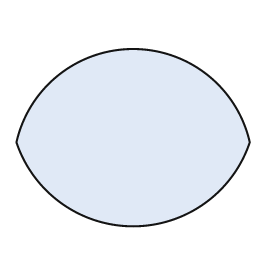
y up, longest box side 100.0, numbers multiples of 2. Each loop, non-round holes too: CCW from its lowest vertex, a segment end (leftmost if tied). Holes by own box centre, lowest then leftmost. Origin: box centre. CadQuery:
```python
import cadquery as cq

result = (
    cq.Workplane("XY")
    .moveTo(-50.0, -2.0)
    .threePointArc((0.0, -38.0), (50.0, -2.0))
    .threePointArc((0.0, 38.0), (-50.0, -2.0))
    .close()
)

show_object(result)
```